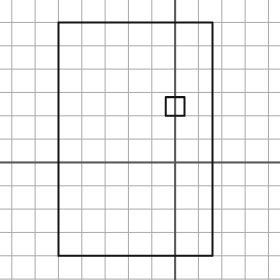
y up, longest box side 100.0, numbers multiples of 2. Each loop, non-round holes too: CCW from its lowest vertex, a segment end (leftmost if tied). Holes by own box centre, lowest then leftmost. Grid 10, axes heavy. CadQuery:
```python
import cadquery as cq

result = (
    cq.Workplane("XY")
    .moveTo(-50.0, -40.0)
    .lineTo(16.0, -40.0)
    .lineTo(16.0, 60.0)
    .lineTo(-50.0, 60.0)
    .close()
    .moveTo(-4.0, 20.0)
    .lineTo(4.0, 20.0)
    .lineTo(4.0, 28.0)
    .lineTo(-4.0, 28.0)
    .close()
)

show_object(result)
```